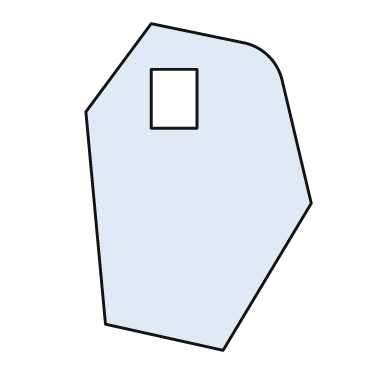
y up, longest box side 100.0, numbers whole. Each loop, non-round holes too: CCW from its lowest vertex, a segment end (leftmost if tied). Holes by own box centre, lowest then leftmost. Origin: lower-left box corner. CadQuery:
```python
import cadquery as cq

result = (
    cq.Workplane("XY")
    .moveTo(42.0, 0.0)
    .lineTo(69.0, 45.0)
    .lineTo(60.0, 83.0)
    .threePointArc((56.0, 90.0), (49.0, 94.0))
    .lineTo(20.0, 100.0)
    .lineTo(0.0, 73.0)
    .lineTo(6.0, 8.0)
    .close()
    .moveTo(20.0, 68.0)
    .lineTo(34.0, 68.0)
    .lineTo(34.0, 86.0)
    .lineTo(20.0, 86.0)
    .close()
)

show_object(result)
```